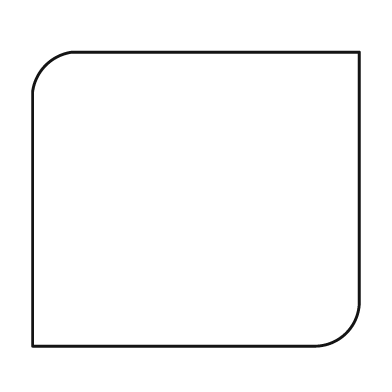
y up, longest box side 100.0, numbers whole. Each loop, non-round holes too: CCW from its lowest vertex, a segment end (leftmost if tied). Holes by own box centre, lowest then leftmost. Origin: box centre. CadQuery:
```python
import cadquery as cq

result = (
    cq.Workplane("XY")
    .moveTo(-50.0, -45.0)
    .lineTo(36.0, -45.0)
    .threePointArc((46.0, -41.0), (50.0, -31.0))
    .lineTo(50.0, 45.0)
    .lineTo(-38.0, 45.0)
    .threePointArc((-46.0, 41.0), (-50.0, 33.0))
    .close()
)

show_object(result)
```